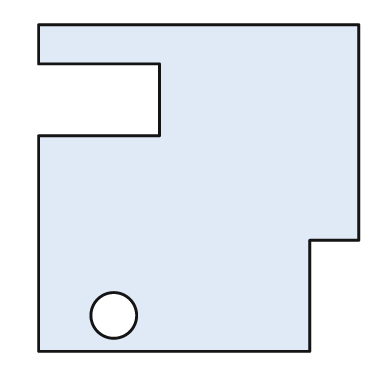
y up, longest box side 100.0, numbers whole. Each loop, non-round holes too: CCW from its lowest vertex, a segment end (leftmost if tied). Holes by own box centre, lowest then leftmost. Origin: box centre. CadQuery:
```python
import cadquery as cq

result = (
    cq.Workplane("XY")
    .moveTo(-49.0, -50.0)
    .lineTo(34.0, -50.0)
    .lineTo(34.0, -16.0)
    .lineTo(49.0, -16.0)
    .lineTo(49.0, 50.0)
    .lineTo(-49.0, 50.0)
    .lineTo(-49.0, 38.0)
    .lineTo(-12.0, 38.0)
    .lineTo(-12.0, 16.0)
    .lineTo(-49.0, 16.0)
    .close()
    .moveTo(-26.0, -39.0)
    .circle(7.0)
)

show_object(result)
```